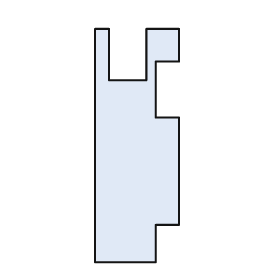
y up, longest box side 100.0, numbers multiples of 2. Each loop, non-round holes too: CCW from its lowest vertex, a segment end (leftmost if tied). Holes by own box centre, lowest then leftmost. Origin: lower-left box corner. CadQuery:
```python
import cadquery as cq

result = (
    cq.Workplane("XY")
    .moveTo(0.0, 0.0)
    .lineTo(26.0, 0.0)
    .lineTo(26.0, 16.0)
    .lineTo(36.0, 16.0)
    .lineTo(36.0, 62.0)
    .lineTo(26.0, 62.0)
    .lineTo(26.0, 86.0)
    .lineTo(36.0, 86.0)
    .lineTo(36.0, 100.0)
    .lineTo(22.0, 100.0)
    .lineTo(22.0, 78.0)
    .lineTo(6.0, 78.0)
    .lineTo(6.0, 100.0)
    .lineTo(0.0, 100.0)
    .close()
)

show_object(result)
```